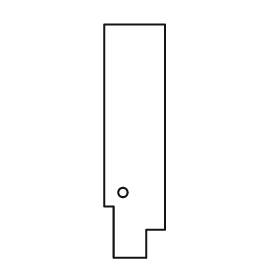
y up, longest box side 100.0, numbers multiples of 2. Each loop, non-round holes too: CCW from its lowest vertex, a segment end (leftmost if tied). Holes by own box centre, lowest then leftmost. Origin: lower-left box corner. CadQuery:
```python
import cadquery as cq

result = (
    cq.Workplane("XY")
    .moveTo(4.0, 0.0)
    .lineTo(18.0, 0.0)
    .lineTo(18.0, 12.0)
    .lineTo(26.0, 12.0)
    .lineTo(26.0, 100.0)
    .lineTo(0.0, 100.0)
    .lineTo(0.0, 22.0)
    .lineTo(4.0, 22.0)
    .close()
    .moveTo(8.0, 28.0)
    .circle(2.0)
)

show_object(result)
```